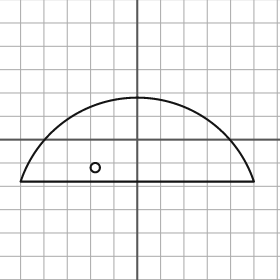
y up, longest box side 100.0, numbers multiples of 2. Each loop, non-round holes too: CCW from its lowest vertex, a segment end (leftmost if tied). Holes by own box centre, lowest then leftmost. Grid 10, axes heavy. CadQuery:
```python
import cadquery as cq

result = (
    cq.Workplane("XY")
    .moveTo(-50.0, -18.0)
    .lineTo(50.0, -18.0)
    .threePointArc((0.0, 18.0), (-50.0, -18.0))
    .close()
    .moveTo(-18.0, -12.0)
    .circle(2.0)
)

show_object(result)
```